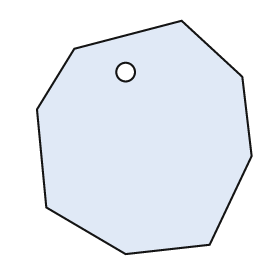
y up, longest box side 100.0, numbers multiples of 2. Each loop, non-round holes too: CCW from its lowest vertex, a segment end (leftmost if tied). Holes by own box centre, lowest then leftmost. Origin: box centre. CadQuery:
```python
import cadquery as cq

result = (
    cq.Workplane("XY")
    .moveTo(-8.0, -50.0)
    .lineTo(28.0, -46.0)
    .lineTo(46.0, -8.0)
    .lineTo(42.0, 26.0)
    .lineTo(16.0, 50.0)
    .lineTo(-30.0, 38.0)
    .lineTo(-46.0, 12.0)
    .lineTo(-42.0, -30.0)
    .close()
    .moveTo(-8.0, 28.0)
    .circle(4.0)
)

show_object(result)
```